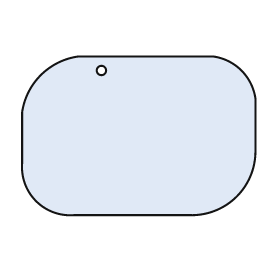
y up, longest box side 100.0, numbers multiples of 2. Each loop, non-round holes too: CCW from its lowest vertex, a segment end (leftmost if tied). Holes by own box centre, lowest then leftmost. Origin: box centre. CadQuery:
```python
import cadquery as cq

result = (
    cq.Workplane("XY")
    .moveTo(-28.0, -34.0)
    .lineTo(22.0, -34.0)
    .threePointArc((42.0, -26.0), (50.0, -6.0))
    .lineTo(50.0, 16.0)
    .threePointArc((44.0, 28.0), (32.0, 34.0))
    .lineTo(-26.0, 34.0)
    .threePointArc((-42.0, 26.0), (-50.0, 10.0))
    .lineTo(-50.0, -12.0)
    .threePointArc((-44.0, -28.0), (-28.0, -34.0))
    .close()
    .moveTo(-16.0, 28.0)
    .circle(2.0)
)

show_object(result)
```